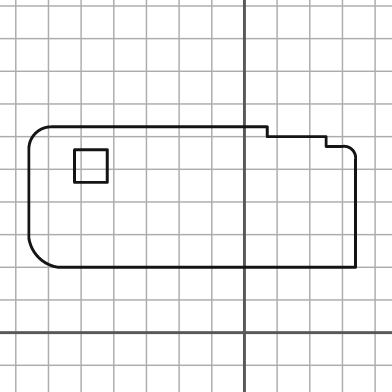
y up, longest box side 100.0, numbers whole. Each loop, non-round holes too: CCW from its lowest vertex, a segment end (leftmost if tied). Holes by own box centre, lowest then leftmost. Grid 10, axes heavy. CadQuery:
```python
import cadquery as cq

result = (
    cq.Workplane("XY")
    .moveTo(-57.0, 20.0)
    .lineTo(34.0, 20.0)
    .lineTo(34.0, 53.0)
    .threePointArc((33.0, 56.0), (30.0, 57.0))
    .lineTo(25.0, 57.0)
    .lineTo(25.0, 60.0)
    .lineTo(7.0, 60.0)
    .lineTo(7.0, 63.0)
    .lineTo(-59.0, 63.0)
    .threePointArc((-64.0, 61.0), (-66.0, 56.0))
    .lineTo(-66.0, 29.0)
    .threePointArc((-63.0, 23.0), (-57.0, 20.0))
    .close()
    .moveTo(-52.0, 46.0)
    .lineTo(-42.0, 46.0)
    .lineTo(-42.0, 56.0)
    .lineTo(-52.0, 56.0)
    .close()
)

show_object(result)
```